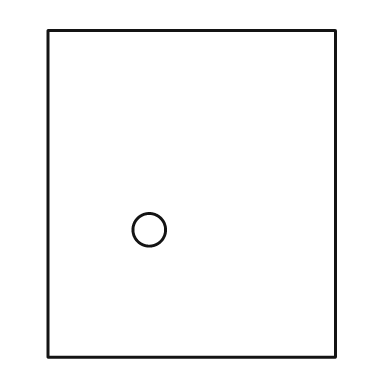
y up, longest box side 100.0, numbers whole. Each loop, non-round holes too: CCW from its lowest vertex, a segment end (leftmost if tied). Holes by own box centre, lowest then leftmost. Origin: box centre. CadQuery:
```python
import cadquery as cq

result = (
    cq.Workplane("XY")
    .moveTo(-44.0, -50.0)
    .lineTo(44.0, -50.0)
    .lineTo(44.0, 50.0)
    .lineTo(-44.0, 50.0)
    .close()
    .moveTo(-13.0, -11.0)
    .circle(5.0)
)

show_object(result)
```